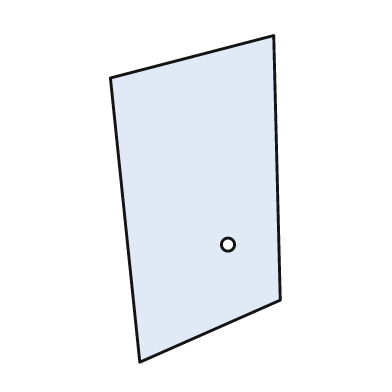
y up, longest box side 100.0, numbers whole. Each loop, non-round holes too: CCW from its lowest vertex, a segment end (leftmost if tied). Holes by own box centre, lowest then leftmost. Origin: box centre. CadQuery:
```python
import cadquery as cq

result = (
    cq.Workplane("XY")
    .moveTo(-17.0, -50.0)
    .lineTo(26.0, -31.0)
    .lineTo(24.0, 50.0)
    .lineTo(-26.0, 37.0)
    .close()
    .moveTo(10.0, -14.0)
    .circle(2.0)
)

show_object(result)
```